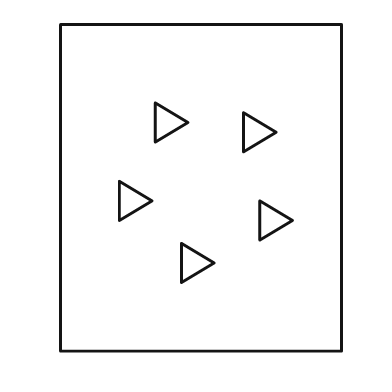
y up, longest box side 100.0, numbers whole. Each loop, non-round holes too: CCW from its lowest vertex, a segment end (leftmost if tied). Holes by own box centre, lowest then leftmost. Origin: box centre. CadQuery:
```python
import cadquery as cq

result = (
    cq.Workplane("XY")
    .moveTo(-43.0, -50.0)
    .lineTo(43.0, -50.0)
    .lineTo(43.0, 50.0)
    .lineTo(-43.0, 50.0)
    .close()
    .moveTo(-6.0, -29.0)
    .lineTo(4.0, -23.0)
    .lineTo(-6.0, -17.0)
    .close()
    .moveTo(18.0, -16.0)
    .lineTo(28.0, -10.0)
    .lineTo(18.0, -4.0)
    .close()
    .moveTo(-25.0, -10.0)
    .lineTo(-15.0, -4.0)
    .lineTo(-25.0, 2.0)
    .close()
    .moveTo(13.0, 11.0)
    .lineTo(23.0, 17.0)
    .lineTo(13.0, 23.0)
    .close()
    .moveTo(-14.0, 14.0)
    .lineTo(-4.0, 20.0)
    .lineTo(-14.0, 26.0)
    .close()
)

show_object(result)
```